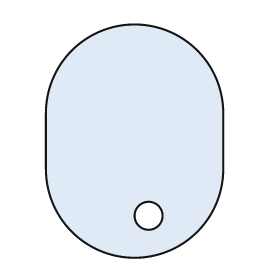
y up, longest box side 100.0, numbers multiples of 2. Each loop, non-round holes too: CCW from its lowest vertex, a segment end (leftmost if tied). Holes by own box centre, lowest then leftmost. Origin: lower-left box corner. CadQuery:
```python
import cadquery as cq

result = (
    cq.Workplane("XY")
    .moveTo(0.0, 38.0)
    .threePointArc((38.0, 0.0), (76.0, 38.0))
    .lineTo(76.0, 62.0)
    .threePointArc((38.0, 100.0), (0.0, 62.0))
    .close()
    .moveTo(44.0, 18.0)
    .circle(6.0)
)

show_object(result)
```